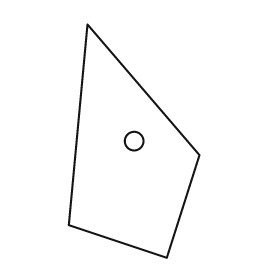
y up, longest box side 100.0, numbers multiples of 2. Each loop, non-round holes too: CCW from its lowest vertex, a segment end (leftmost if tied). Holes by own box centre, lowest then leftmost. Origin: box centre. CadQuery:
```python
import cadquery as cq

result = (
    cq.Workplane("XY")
    .moveTo(14.0, -50.0)
    .lineTo(28.0, -6.0)
    .lineTo(-20.0, 50.0)
    .lineTo(-28.0, -36.0)
    .close()
    .moveTo(0.0, 0.0)
    .circle(4.0)
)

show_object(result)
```